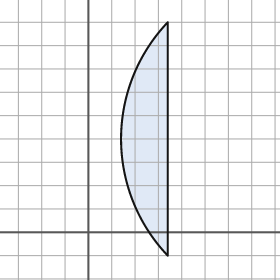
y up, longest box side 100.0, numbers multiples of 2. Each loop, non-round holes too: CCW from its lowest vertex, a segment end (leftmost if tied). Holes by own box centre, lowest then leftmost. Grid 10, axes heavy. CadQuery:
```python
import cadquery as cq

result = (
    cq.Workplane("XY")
    .moveTo(34.0, -10.0)
    .lineTo(34.0, 90.0)
    .threePointArc((14.0, 40.0), (34.0, -10.0))
    .close()
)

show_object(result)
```